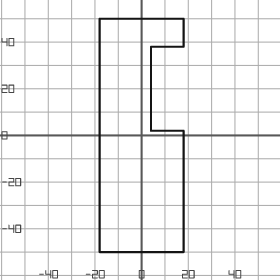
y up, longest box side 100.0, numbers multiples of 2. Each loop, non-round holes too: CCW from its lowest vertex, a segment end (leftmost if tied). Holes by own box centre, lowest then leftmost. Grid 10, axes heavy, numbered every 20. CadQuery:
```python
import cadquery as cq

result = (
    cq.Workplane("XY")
    .moveTo(-18.0, -50.0)
    .lineTo(18.0, -50.0)
    .lineTo(18.0, 2.0)
    .lineTo(4.0, 2.0)
    .lineTo(4.0, 38.0)
    .lineTo(18.0, 38.0)
    .lineTo(18.0, 50.0)
    .lineTo(-18.0, 50.0)
    .close()
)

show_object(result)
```